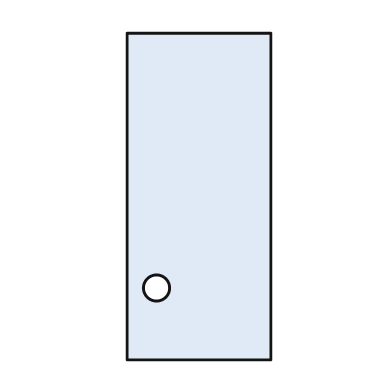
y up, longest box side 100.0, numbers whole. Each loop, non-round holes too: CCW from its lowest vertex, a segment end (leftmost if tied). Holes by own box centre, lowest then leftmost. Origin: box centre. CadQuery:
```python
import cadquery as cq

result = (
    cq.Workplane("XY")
    .moveTo(-22.0, -50.0)
    .lineTo(22.0, -50.0)
    .lineTo(22.0, 50.0)
    .lineTo(-22.0, 50.0)
    .close()
    .moveTo(-13.0, -28.0)
    .circle(4.0)
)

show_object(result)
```